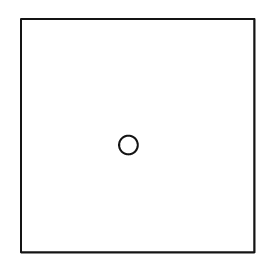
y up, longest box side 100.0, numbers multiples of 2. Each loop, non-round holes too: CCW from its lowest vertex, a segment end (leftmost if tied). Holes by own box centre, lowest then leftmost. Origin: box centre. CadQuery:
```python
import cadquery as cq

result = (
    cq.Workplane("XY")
    .moveTo(-50.0, -50.0)
    .lineTo(50.0, -50.0)
    .lineTo(50.0, 50.0)
    .lineTo(-50.0, 50.0)
    .close()
    .moveTo(-4.0, -4.0)
    .circle(4.0)
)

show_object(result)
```